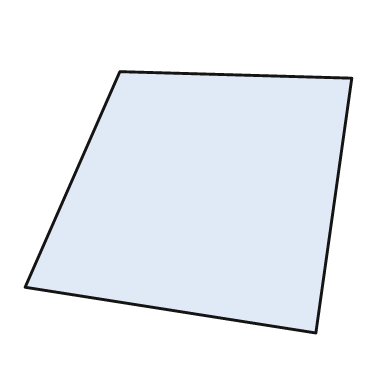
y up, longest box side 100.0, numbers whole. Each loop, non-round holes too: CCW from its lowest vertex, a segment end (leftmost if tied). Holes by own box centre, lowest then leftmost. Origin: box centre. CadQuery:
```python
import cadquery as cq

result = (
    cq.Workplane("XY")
    .moveTo(39.0, -40.0)
    .lineTo(50.0, 38.0)
    .lineTo(-21.0, 40.0)
    .lineTo(-50.0, -26.0)
    .close()
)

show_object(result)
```